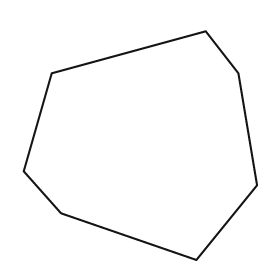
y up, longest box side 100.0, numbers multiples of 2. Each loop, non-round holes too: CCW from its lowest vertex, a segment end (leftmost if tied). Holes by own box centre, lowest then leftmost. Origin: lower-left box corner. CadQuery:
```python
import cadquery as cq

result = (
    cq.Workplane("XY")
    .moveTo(74.0, 0.0)
    .lineTo(100.0, 32.0)
    .lineTo(92.0, 80.0)
    .lineTo(78.0, 98.0)
    .lineTo(12.0, 80.0)
    .lineTo(0.0, 38.0)
    .lineTo(16.0, 20.0)
    .close()
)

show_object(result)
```